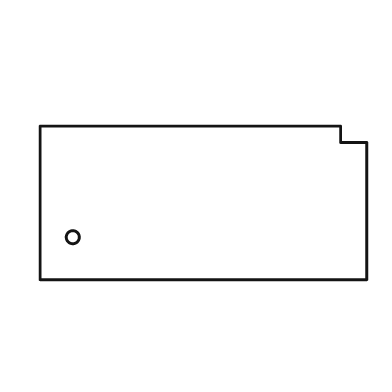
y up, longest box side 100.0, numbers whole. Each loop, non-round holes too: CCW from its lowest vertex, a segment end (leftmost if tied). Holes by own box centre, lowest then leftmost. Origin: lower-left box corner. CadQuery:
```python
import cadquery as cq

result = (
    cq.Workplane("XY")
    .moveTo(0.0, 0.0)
    .lineTo(100.0, 0.0)
    .lineTo(100.0, 42.0)
    .lineTo(92.0, 42.0)
    .lineTo(92.0, 47.0)
    .lineTo(0.0, 47.0)
    .close()
    .moveTo(10.0, 13.0)
    .circle(2.0)
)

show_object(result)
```